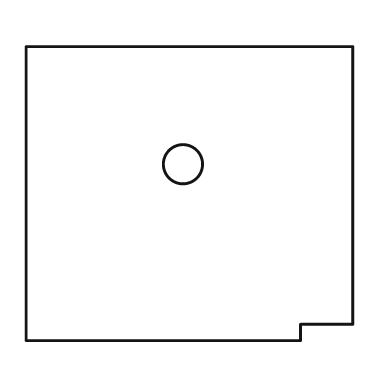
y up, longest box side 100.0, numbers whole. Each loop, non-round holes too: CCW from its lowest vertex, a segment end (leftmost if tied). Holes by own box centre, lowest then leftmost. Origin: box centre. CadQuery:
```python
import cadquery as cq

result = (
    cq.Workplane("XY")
    .moveTo(-50.0, -45.0)
    .lineTo(34.0, -45.0)
    .lineTo(34.0, -40.0)
    .lineTo(50.0, -40.0)
    .lineTo(50.0, 45.0)
    .lineTo(-50.0, 45.0)
    .close()
    .moveTo(-2.0, 9.0)
    .circle(6.0)
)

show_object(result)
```